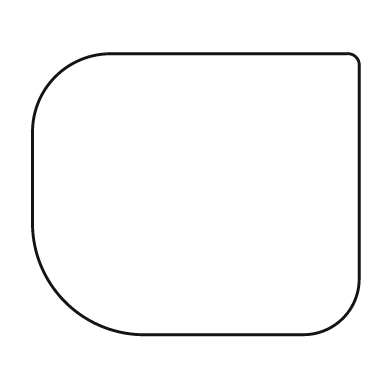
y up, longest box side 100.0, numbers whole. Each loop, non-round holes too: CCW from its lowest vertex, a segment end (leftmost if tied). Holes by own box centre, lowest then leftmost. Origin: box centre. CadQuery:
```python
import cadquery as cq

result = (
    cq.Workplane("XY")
    .moveTo(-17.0, -43.0)
    .lineTo(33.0, -43.0)
    .threePointArc((45.0, -38.0), (50.0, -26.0))
    .lineTo(50.0, 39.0)
    .threePointArc((49.0, 42.0), (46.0, 43.0))
    .lineTo(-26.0, 43.0)
    .threePointArc((-43.0, 36.0), (-50.0, 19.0))
    .lineTo(-50.0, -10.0)
    .threePointArc((-40.0, -33.0), (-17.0, -43.0))
    .close()
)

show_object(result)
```